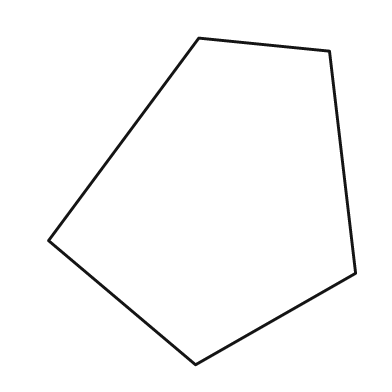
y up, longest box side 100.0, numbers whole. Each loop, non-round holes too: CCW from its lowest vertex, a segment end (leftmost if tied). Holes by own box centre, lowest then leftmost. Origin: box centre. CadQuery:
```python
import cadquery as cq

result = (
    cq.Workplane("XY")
    .moveTo(-2.0, -50.0)
    .lineTo(47.0, -22.0)
    .lineTo(39.0, 46.0)
    .lineTo(-1.0, 50.0)
    .lineTo(-47.0, -12.0)
    .close()
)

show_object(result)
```